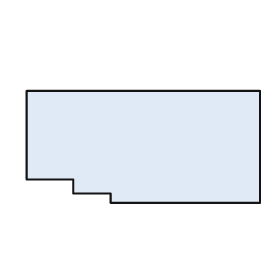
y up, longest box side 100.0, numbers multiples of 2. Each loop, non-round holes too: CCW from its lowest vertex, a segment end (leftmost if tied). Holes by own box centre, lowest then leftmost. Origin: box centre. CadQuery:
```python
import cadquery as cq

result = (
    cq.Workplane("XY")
    .moveTo(-14.0, -24.0)
    .lineTo(50.0, -24.0)
    .lineTo(50.0, 24.0)
    .lineTo(-50.0, 24.0)
    .lineTo(-50.0, -14.0)
    .lineTo(-30.0, -14.0)
    .lineTo(-30.0, -20.0)
    .lineTo(-14.0, -20.0)
    .close()
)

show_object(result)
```